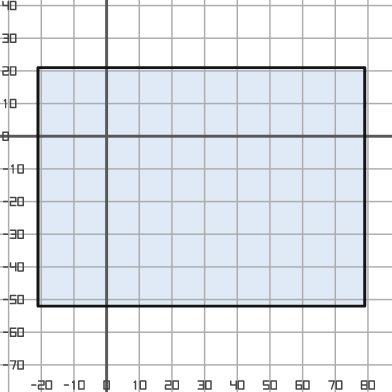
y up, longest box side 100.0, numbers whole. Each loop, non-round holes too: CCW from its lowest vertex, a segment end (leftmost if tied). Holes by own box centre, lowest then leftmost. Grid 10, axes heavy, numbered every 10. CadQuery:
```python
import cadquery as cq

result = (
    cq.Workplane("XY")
    .moveTo(-21.0, -52.0)
    .lineTo(79.0, -52.0)
    .lineTo(79.0, 21.0)
    .lineTo(-21.0, 21.0)
    .close()
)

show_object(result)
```